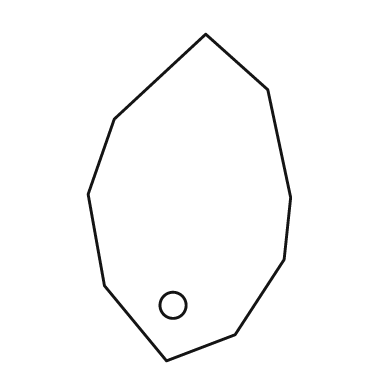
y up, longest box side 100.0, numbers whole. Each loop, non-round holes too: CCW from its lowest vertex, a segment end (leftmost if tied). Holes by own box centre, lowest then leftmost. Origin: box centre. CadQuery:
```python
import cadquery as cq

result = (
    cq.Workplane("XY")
    .moveTo(-7.0, -50.0)
    .lineTo(14.0, -42.0)
    .lineTo(29.0, -19.0)
    .lineTo(31.0, 0.0)
    .lineTo(24.0, 33.0)
    .lineTo(5.0, 50.0)
    .lineTo(-23.0, 24.0)
    .lineTo(-31.0, 1.0)
    .lineTo(-26.0, -27.0)
    .close()
    .moveTo(-5.0, -33.0)
    .circle(4.0)
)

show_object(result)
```